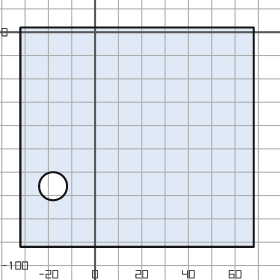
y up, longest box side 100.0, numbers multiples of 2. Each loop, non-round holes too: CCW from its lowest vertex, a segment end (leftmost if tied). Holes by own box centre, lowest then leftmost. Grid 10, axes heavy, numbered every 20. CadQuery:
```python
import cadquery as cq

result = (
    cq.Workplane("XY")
    .moveTo(-32.0, -92.0)
    .lineTo(68.0, -92.0)
    .lineTo(68.0, 2.0)
    .lineTo(-32.0, 2.0)
    .close()
    .moveTo(-18.0, -66.0)
    .circle(6.0)
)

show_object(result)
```